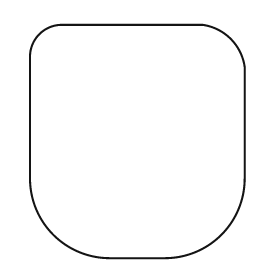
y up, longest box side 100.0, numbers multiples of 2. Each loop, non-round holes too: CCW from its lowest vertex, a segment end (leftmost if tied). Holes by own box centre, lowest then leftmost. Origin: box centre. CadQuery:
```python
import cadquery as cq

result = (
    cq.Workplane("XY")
    .moveTo(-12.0, -50.0)
    .lineTo(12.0, -50.0)
    .threePointArc((36.0, -40.0), (46.0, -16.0))
    .lineTo(46.0, 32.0)
    .threePointArc((40.0, 44.0), (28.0, 50.0))
    .lineTo(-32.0, 50.0)
    .threePointArc((-42.0, 46.0), (-46.0, 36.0))
    .lineTo(-46.0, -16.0)
    .threePointArc((-36.0, -40.0), (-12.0, -50.0))
    .close()
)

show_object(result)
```